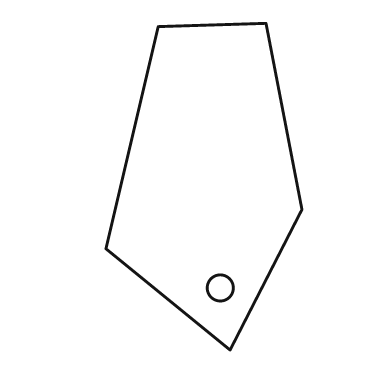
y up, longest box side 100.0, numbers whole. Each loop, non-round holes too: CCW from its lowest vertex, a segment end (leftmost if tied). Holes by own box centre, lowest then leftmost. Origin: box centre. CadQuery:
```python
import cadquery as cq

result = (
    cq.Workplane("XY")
    .moveTo(8.0, -50.0)
    .lineTo(30.0, -7.0)
    .lineTo(19.0, 50.0)
    .lineTo(-14.0, 49.0)
    .lineTo(-30.0, -19.0)
    .close()
    .moveTo(5.0, -31.0)
    .circle(4.0)
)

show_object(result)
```